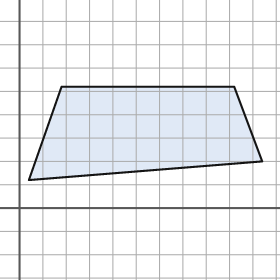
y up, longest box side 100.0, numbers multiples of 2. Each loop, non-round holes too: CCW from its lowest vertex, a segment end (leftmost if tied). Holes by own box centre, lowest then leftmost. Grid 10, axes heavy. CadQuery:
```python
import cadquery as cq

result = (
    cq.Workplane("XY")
    .moveTo(4.0, 12.0)
    .lineTo(104.0, 20.0)
    .lineTo(92.0, 52.0)
    .lineTo(18.0, 52.0)
    .close()
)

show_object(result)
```